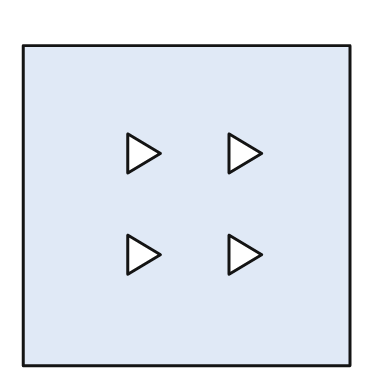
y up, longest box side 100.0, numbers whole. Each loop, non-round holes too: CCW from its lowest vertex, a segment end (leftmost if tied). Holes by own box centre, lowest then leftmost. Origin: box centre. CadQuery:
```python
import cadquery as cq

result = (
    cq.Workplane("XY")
    .moveTo(-50.0, -49.0)
    .lineTo(50.0, -49.0)
    .lineTo(50.0, 49.0)
    .lineTo(-50.0, 49.0)
    .close()
    .moveTo(-18.0, -21.0)
    .lineTo(-8.0, -15.0)
    .lineTo(-18.0, -9.0)
    .close()
    .moveTo(13.0, -21.0)
    .lineTo(23.0, -15.0)
    .lineTo(13.0, -9.0)
    .close()
    .moveTo(-18.0, 10.0)
    .lineTo(-8.0, 16.0)
    .lineTo(-18.0, 22.0)
    .close()
    .moveTo(13.0, 10.0)
    .lineTo(23.0, 16.0)
    .lineTo(13.0, 22.0)
    .close()
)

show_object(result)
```